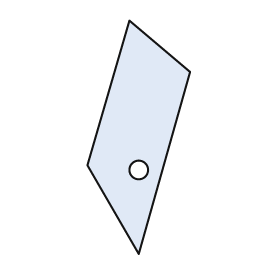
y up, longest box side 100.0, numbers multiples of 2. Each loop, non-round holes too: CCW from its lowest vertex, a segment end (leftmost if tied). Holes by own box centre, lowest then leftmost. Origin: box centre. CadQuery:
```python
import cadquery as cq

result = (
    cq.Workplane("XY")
    .moveTo(0.0, -50.0)
    .lineTo(22.0, 28.0)
    .lineTo(-4.0, 50.0)
    .lineTo(-22.0, -12.0)
    .close()
    .moveTo(0.0, -14.0)
    .circle(4.0)
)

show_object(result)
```